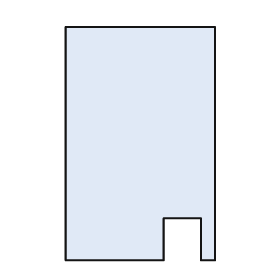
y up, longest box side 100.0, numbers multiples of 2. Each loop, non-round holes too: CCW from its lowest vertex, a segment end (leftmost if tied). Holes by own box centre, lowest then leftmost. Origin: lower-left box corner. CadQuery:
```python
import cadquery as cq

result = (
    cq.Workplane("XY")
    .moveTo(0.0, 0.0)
    .lineTo(42.0, 0.0)
    .lineTo(42.0, 18.0)
    .lineTo(58.0, 18.0)
    .lineTo(58.0, 0.0)
    .lineTo(64.0, 0.0)
    .lineTo(64.0, 100.0)
    .lineTo(0.0, 100.0)
    .close()
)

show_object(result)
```